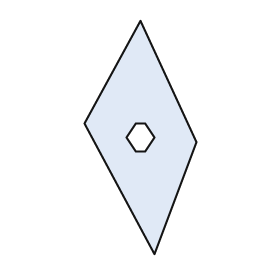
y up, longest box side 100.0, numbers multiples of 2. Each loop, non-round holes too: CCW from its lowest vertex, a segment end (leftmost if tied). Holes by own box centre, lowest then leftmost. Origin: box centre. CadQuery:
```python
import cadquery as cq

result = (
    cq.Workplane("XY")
    .moveTo(6.0, -50.0)
    .lineTo(24.0, -2.0)
    .lineTo(0.0, 50.0)
    .lineTo(-24.0, 6.0)
    .close()
    .moveTo(-2.0, -6.0)
    .lineTo(2.0, -6.0)
    .lineTo(6.0, 0.0)
    .lineTo(2.0, 6.0)
    .lineTo(-2.0, 6.0)
    .lineTo(-6.0, 0.0)
    .close()
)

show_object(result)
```